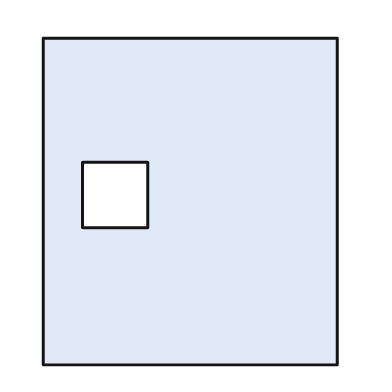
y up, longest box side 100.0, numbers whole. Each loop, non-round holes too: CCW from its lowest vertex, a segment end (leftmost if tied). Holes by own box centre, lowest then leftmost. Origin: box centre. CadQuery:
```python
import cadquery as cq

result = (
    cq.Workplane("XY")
    .moveTo(-45.0, -50.0)
    .lineTo(45.0, -50.0)
    .lineTo(45.0, 50.0)
    .lineTo(-45.0, 50.0)
    .close()
    .moveTo(-33.0, -8.0)
    .lineTo(-13.0, -8.0)
    .lineTo(-13.0, 12.0)
    .lineTo(-33.0, 12.0)
    .close()
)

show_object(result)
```